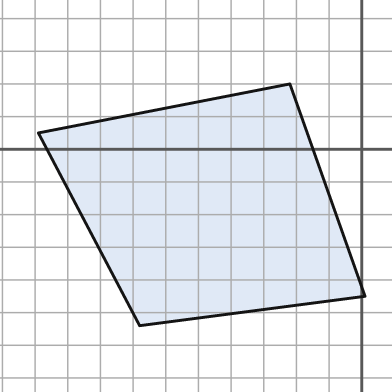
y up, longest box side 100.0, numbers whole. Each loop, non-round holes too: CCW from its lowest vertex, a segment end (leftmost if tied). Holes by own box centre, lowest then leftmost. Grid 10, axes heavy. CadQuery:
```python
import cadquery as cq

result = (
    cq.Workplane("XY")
    .moveTo(-68.0, -54.0)
    .lineTo(1.0, -45.0)
    .lineTo(-22.0, 20.0)
    .lineTo(-99.0, 5.0)
    .close()
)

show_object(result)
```